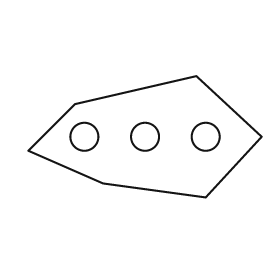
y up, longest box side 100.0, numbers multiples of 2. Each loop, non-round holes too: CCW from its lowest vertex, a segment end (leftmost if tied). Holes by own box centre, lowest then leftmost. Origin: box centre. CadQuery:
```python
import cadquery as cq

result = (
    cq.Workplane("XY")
    .moveTo(26.0, -26.0)
    .lineTo(50.0, 0.0)
    .lineTo(22.0, 26.0)
    .lineTo(-30.0, 14.0)
    .lineTo(-50.0, -6.0)
    .lineTo(-18.0, -20.0)
    .close()
    .moveTo(-26.0, 0.0)
    .circle(6.0)
    .moveTo(0.0, 0.0)
    .circle(6.0)
    .moveTo(26.0, 0.0)
    .circle(6.0)
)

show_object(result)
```